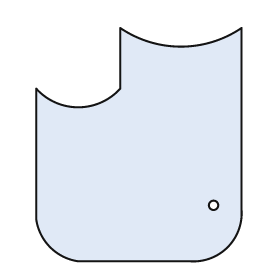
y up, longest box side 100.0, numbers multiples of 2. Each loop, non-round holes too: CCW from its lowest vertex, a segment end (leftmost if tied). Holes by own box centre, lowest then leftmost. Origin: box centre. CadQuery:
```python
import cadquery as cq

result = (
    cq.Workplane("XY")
    .moveTo(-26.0, -50.0)
    .lineTo(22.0, -50.0)
    .threePointArc((38.0, -44.0), (44.0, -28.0))
    .lineTo(44.0, 50.0)
    .threePointArc((18.0, 42.0), (-8.0, 50.0))
    .lineTo(-8.0, 24.0)
    .threePointArc((-26.0, 16.0), (-44.0, 24.0))
    .lineTo(-44.0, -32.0)
    .threePointArc((-38.0, -44.0), (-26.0, -50.0))
    .close()
    .moveTo(32.0, -26.0)
    .circle(2.0)
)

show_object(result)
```